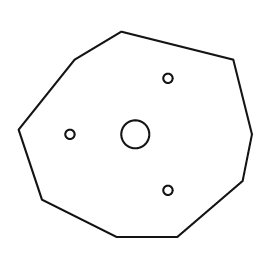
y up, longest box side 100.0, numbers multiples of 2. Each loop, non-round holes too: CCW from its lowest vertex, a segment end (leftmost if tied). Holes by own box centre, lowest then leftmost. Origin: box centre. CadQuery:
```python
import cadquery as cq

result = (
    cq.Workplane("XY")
    .moveTo(-8.0, -44.0)
    .lineTo(18.0, -44.0)
    .lineTo(46.0, -20.0)
    .lineTo(50.0, 0.0)
    .lineTo(42.0, 32.0)
    .lineTo(-6.0, 44.0)
    .lineTo(-26.0, 32.0)
    .lineTo(-50.0, 2.0)
    .lineTo(-40.0, -28.0)
    .close()
    .moveTo(14.0, -24.0)
    .circle(2.0)
    .moveTo(-28.0, 0.0)
    .circle(2.0)
    .moveTo(0.0, 0.0)
    .circle(6.0)
    .moveTo(14.0, 24.0)
    .circle(2.0)
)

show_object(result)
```